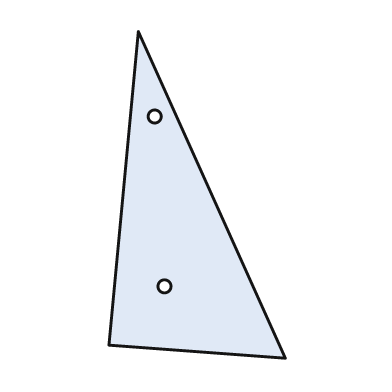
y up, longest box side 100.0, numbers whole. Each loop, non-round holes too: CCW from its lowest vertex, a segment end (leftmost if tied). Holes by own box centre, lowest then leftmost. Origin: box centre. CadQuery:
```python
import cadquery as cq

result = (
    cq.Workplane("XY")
    .moveTo(27.0, -50.0)
    .lineTo(-18.0, 50.0)
    .lineTo(-27.0, -46.0)
    .close()
    .moveTo(-10.0, -28.0)
    .circle(2.0)
    .moveTo(-13.0, 24.0)
    .circle(2.0)
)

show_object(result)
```